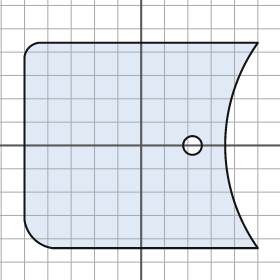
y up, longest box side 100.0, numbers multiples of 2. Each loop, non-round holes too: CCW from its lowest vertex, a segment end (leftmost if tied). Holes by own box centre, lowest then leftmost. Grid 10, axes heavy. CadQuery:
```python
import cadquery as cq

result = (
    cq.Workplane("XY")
    .moveTo(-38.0, -44.0)
    .lineTo(50.0, -44.0)
    .threePointArc((36.0, 0.0), (50.0, 44.0))
    .lineTo(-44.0, 44.0)
    .threePointArc((-48.0, 42.0), (-50.0, 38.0))
    .lineTo(-50.0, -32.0)
    .threePointArc((-46.0, -40.0), (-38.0, -44.0))
    .close()
    .moveTo(22.0, 0.0)
    .circle(4.0)
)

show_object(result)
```